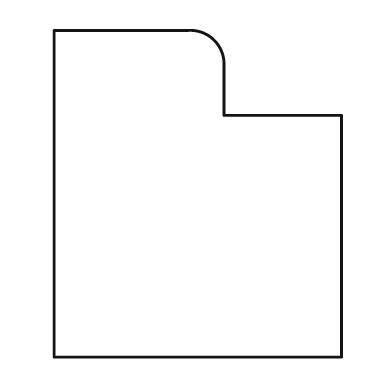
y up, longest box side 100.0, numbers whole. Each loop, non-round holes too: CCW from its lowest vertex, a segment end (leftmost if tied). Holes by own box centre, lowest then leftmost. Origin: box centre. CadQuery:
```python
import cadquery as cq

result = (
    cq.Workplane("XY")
    .moveTo(-44.0, -50.0)
    .lineTo(44.0, -50.0)
    .lineTo(44.0, 24.0)
    .lineTo(8.0, 24.0)
    .lineTo(8.0, 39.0)
    .threePointArc((5.0, 47.0), (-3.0, 50.0))
    .lineTo(-44.0, 50.0)
    .close()
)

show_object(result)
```